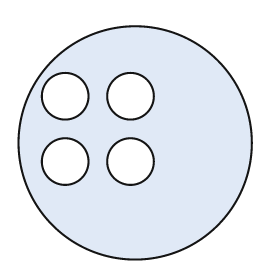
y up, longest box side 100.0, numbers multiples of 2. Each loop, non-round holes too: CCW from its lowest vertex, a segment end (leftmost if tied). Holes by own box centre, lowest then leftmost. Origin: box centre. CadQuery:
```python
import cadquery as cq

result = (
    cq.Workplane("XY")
    .moveTo(0.0, 0.0)
    .circle(50.0)
    .moveTo(-30.0, -8.0)
    .circle(10.0)
    .moveTo(-2.0, -8.0)
    .circle(10.0)
    .moveTo(-30.0, 20.0)
    .circle(10.0)
    .moveTo(-2.0, 20.0)
    .circle(10.0)
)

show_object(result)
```